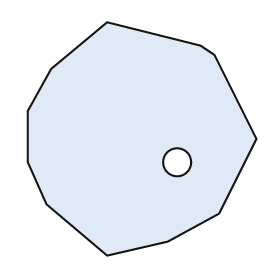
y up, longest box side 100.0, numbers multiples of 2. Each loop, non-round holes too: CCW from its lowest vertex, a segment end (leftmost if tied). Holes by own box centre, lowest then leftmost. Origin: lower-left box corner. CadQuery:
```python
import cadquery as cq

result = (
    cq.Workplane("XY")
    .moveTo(34.0, 0.0)
    .lineTo(60.0, 6.0)
    .lineTo(82.0, 18.0)
    .lineTo(98.0, 50.0)
    .lineTo(80.0, 86.0)
    .lineTo(74.0, 90.0)
    .lineTo(34.0, 100.0)
    .lineTo(10.0, 80.0)
    .lineTo(0.0, 62.0)
    .lineTo(0.0, 40.0)
    .lineTo(8.0, 22.0)
    .close()
    .moveTo(64.0, 40.0)
    .circle(6.0)
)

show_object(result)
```